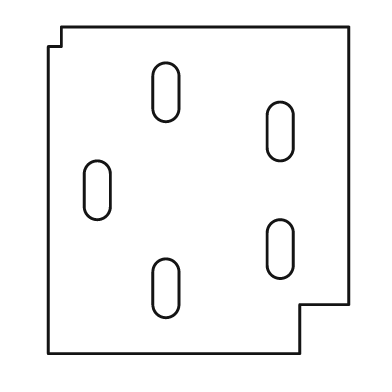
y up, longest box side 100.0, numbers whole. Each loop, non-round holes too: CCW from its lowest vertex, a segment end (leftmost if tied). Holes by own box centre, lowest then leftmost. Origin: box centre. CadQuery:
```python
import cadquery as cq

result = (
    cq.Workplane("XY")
    .moveTo(-46.0, -50.0)
    .lineTo(31.0, -50.0)
    .lineTo(31.0, -35.0)
    .lineTo(46.0, -35.0)
    .lineTo(46.0, 50.0)
    .lineTo(-42.0, 50.0)
    .lineTo(-42.0, 44.0)
    .lineTo(-46.0, 44.0)
    .close()
    .moveTo(-14.0, -35.0)
    .threePointArc((-10.0, -39.0), (-6.0, -35.0))
    .lineTo(-6.0, -25.0)
    .threePointArc((-10.0, -21.0), (-14.0, -25.0))
    .close()
    .moveTo(21.0, -23.0)
    .threePointArc((25.0, -27.0), (29.0, -23.0))
    .lineTo(29.0, -13.0)
    .threePointArc((25.0, -9.0), (21.0, -13.0))
    .close()
    .moveTo(-35.0, -5.0)
    .threePointArc((-31.0, -9.0), (-27.0, -5.0))
    .lineTo(-27.0, 5.0)
    .threePointArc((-31.0, 9.0), (-35.0, 5.0))
    .close()
    .moveTo(21.0, 13.0)
    .threePointArc((25.0, 9.0), (29.0, 13.0))
    .lineTo(29.0, 23.0)
    .threePointArc((25.0, 27.0), (21.0, 23.0))
    .close()
    .moveTo(-14.0, 25.0)
    .threePointArc((-10.0, 21.0), (-6.0, 25.0))
    .lineTo(-6.0, 35.0)
    .threePointArc((-10.0, 39.0), (-14.0, 35.0))
    .close()
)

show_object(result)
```